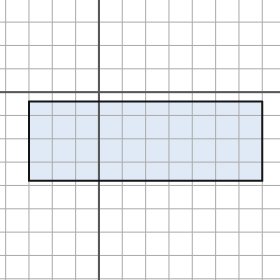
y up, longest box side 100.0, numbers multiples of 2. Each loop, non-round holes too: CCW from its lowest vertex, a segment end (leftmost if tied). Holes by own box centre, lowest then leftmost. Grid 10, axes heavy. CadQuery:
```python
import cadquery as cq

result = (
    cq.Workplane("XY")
    .moveTo(-30.0, -38.0)
    .lineTo(70.0, -38.0)
    .lineTo(70.0, -4.0)
    .lineTo(-30.0, -4.0)
    .close()
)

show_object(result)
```